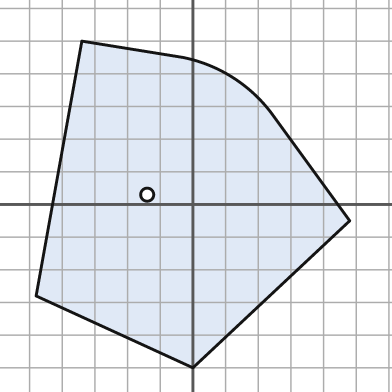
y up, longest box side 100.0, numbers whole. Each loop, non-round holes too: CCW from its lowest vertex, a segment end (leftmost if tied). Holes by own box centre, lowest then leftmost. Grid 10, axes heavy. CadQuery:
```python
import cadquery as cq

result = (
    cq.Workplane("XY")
    .moveTo(0.0, -50.0)
    .lineTo(48.0, -5.0)
    .lineTo(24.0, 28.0)
    .threePointArc((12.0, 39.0), (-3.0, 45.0))
    .lineTo(-34.0, 50.0)
    .lineTo(-48.0, -28.0)
    .close()
    .moveTo(-14.0, 3.0)
    .circle(2.0)
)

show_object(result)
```